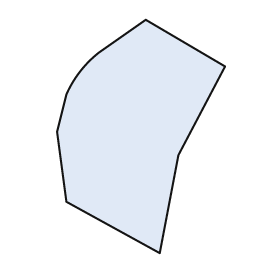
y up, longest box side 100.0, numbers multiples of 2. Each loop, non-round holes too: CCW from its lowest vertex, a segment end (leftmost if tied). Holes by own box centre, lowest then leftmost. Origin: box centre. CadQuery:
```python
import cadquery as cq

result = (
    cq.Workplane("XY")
    .moveTo(8.0, -50.0)
    .lineTo(16.0, -8.0)
    .lineTo(36.0, 30.0)
    .lineTo(2.0, 50.0)
    .lineTo(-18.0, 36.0)
    .threePointArc((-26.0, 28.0), (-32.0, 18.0))
    .lineTo(-36.0, 2.0)
    .lineTo(-32.0, -28.0)
    .close()
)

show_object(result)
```